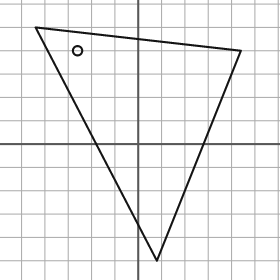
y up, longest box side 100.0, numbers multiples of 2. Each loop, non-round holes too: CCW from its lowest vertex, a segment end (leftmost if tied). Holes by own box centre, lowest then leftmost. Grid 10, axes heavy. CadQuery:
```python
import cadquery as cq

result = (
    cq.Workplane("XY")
    .moveTo(8.0, -50.0)
    .lineTo(44.0, 40.0)
    .lineTo(-44.0, 50.0)
    .close()
    .moveTo(-26.0, 40.0)
    .circle(2.0)
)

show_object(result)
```